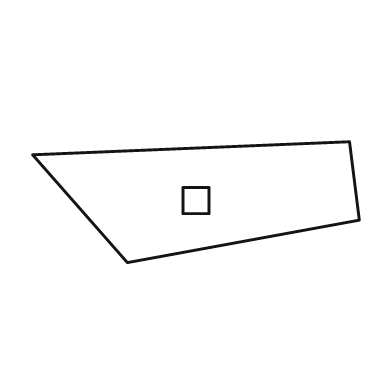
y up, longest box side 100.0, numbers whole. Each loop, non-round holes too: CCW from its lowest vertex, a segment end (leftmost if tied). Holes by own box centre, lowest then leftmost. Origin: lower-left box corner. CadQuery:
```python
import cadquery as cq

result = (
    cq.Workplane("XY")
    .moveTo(29.0, 0.0)
    .lineTo(100.0, 13.0)
    .lineTo(97.0, 37.0)
    .lineTo(0.0, 33.0)
    .close()
    .moveTo(46.0, 15.0)
    .lineTo(54.0, 15.0)
    .lineTo(54.0, 23.0)
    .lineTo(46.0, 23.0)
    .close()
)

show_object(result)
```